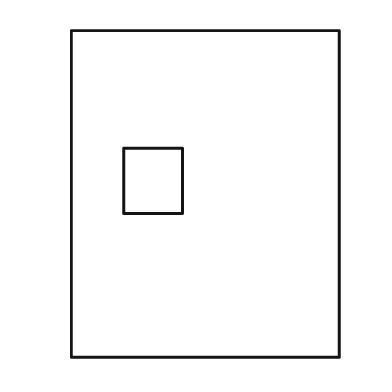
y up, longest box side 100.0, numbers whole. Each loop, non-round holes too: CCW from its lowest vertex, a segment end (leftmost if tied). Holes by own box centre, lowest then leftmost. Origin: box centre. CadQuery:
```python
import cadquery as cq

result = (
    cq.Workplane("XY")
    .moveTo(-41.0, -50.0)
    .lineTo(41.0, -50.0)
    .lineTo(41.0, 50.0)
    .lineTo(-41.0, 50.0)
    .close()
    .moveTo(-25.0, -6.0)
    .lineTo(-7.0, -6.0)
    .lineTo(-7.0, 14.0)
    .lineTo(-25.0, 14.0)
    .close()
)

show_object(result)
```